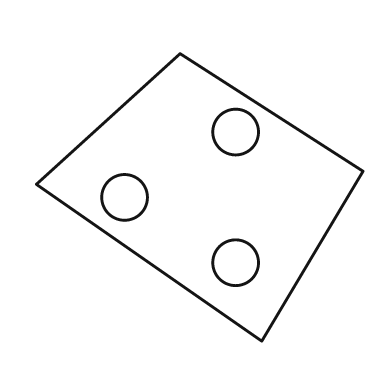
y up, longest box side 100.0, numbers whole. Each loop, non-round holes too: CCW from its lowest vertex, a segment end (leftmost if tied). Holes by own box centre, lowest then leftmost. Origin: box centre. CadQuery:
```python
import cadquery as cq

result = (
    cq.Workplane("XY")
    .moveTo(19.0, -44.0)
    .lineTo(50.0, 8.0)
    .lineTo(-6.0, 44.0)
    .lineTo(-50.0, 4.0)
    .close()
    .moveTo(11.0, -20.0)
    .circle(7.0)
    .moveTo(-23.0, 0.0)
    .circle(7.0)
    .moveTo(11.0, 20.0)
    .circle(7.0)
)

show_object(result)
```